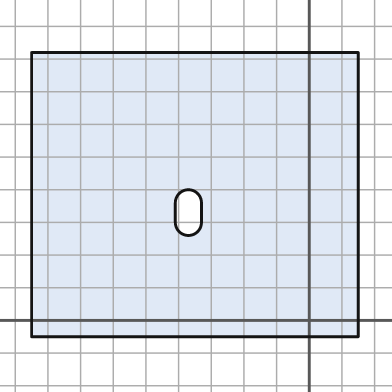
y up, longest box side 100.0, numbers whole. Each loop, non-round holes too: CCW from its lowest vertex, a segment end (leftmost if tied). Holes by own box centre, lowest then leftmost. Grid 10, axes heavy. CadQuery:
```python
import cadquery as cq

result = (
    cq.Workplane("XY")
    .moveTo(-85.0, -5.0)
    .lineTo(15.0, -5.0)
    .lineTo(15.0, 82.0)
    .lineTo(-85.0, 82.0)
    .close()
    .moveTo(-41.0, 30.0)
    .threePointArc((-37.0, 26.0), (-33.0, 30.0))
    .lineTo(-33.0, 36.0)
    .threePointArc((-37.0, 40.0), (-41.0, 36.0))
    .close()
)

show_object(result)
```